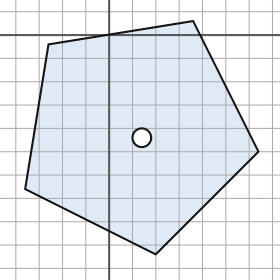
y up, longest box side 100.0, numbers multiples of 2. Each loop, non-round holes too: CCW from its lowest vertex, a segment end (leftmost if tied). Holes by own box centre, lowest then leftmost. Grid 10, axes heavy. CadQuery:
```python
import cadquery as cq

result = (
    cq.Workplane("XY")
    .moveTo(20.0, -94.0)
    .lineTo(64.0, -50.0)
    .lineTo(36.0, 6.0)
    .lineTo(-26.0, -4.0)
    .lineTo(-36.0, -66.0)
    .close()
    .moveTo(14.0, -44.0)
    .circle(4.0)
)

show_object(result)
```